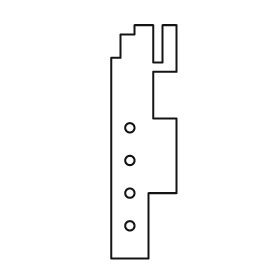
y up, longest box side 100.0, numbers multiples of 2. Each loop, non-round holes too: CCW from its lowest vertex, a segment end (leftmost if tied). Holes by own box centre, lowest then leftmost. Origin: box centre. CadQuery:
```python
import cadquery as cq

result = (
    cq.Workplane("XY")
    .moveTo(-14.0, -50.0)
    .lineTo(2.0, -50.0)
    .lineTo(2.0, -22.0)
    .lineTo(14.0, -22.0)
    .lineTo(14.0, 10.0)
    .lineTo(4.0, 10.0)
    .lineTo(4.0, 30.0)
    .lineTo(14.0, 30.0)
    .lineTo(14.0, 50.0)
    .lineTo(8.0, 50.0)
    .lineTo(8.0, 34.0)
    .lineTo(4.0, 34.0)
    .lineTo(4.0, 50.0)
    .lineTo(-4.0, 50.0)
    .lineTo(-4.0, 46.0)
    .lineTo(-10.0, 46.0)
    .lineTo(-10.0, 36.0)
    .lineTo(-14.0, 36.0)
    .close()
    .moveTo(-6.0, -36.0)
    .circle(2.0)
    .moveTo(-6.0, -22.0)
    .circle(2.0)
    .moveTo(-6.0, -8.0)
    .circle(2.0)
    .moveTo(-6.0, 6.0)
    .circle(2.0)
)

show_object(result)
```